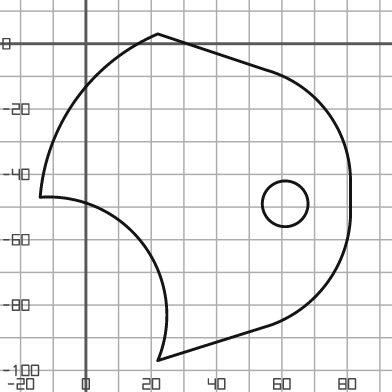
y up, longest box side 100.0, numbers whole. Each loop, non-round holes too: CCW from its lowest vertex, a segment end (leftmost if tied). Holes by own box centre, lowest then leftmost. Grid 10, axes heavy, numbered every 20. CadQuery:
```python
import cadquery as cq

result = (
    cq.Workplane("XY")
    .moveTo(22.0, -97.0)
    .lineTo(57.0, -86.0)
    .threePointArc((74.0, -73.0), (81.0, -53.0))
    .lineTo(81.0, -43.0)
    .threePointArc((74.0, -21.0), (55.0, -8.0))
    .lineTo(22.0, 3.0)
    .threePointArc((-3.0, -17.0), (-14.0, -47.0))
    .threePointArc((18.0, -62.0), (22.0, -97.0))
    .close()
    .moveTo(61.0, -49.0)
    .circle(7.0)
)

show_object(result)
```